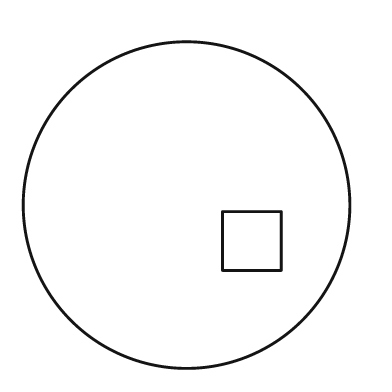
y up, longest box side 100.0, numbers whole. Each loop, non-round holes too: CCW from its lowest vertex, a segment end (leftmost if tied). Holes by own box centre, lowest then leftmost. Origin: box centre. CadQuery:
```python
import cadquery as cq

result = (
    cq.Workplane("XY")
    .moveTo(0.0, 0.0)
    .circle(50.0)
    .moveTo(11.0, -20.0)
    .lineTo(29.0, -20.0)
    .lineTo(29.0, -2.0)
    .lineTo(11.0, -2.0)
    .close()
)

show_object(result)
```